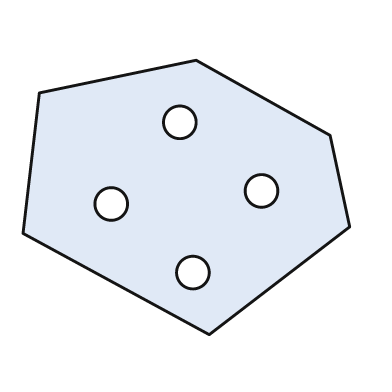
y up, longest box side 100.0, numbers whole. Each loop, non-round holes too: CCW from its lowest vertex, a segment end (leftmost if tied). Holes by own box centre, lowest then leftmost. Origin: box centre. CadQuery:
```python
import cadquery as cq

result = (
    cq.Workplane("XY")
    .moveTo(7.0, -42.0)
    .lineTo(50.0, -9.0)
    .lineTo(44.0, 19.0)
    .lineTo(3.0, 42.0)
    .lineTo(-45.0, 32.0)
    .lineTo(-50.0, -11.0)
    .close()
    .moveTo(2.0, -23.0)
    .circle(5.0)
    .moveTo(-23.0, -2.0)
    .circle(5.0)
    .moveTo(23.0, 2.0)
    .circle(5.0)
    .moveTo(-2.0, 23.0)
    .circle(5.0)
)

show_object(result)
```